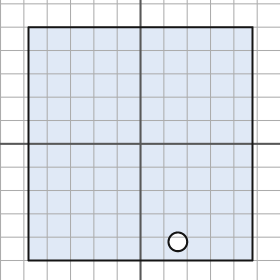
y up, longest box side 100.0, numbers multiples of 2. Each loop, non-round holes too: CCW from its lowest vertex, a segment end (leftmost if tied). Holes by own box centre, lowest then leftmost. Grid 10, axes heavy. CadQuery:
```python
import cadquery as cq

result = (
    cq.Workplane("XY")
    .moveTo(-48.0, -50.0)
    .lineTo(48.0, -50.0)
    .lineTo(48.0, 50.0)
    .lineTo(-48.0, 50.0)
    .close()
    .moveTo(16.0, -42.0)
    .circle(4.0)
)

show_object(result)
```